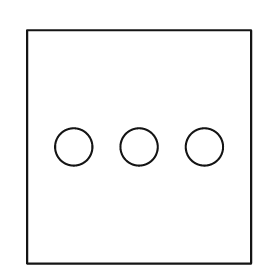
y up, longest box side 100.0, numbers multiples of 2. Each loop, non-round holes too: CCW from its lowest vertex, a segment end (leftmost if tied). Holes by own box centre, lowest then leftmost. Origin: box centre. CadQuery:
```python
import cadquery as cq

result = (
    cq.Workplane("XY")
    .moveTo(-48.0, -50.0)
    .lineTo(48.0, -50.0)
    .lineTo(48.0, 50.0)
    .lineTo(-48.0, 50.0)
    .close()
    .moveTo(-28.0, 0.0)
    .circle(8.0)
    .moveTo(0.0, 0.0)
    .circle(8.0)
    .moveTo(28.0, 0.0)
    .circle(8.0)
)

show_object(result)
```